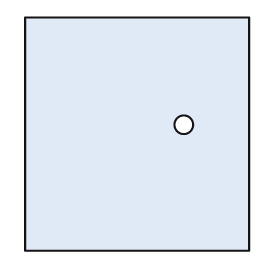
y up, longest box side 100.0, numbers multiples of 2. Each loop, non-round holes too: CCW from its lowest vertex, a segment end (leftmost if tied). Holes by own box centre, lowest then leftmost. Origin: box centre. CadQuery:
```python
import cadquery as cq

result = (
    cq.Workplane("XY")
    .moveTo(-48.0, -50.0)
    .lineTo(48.0, -50.0)
    .lineTo(48.0, 50.0)
    .lineTo(-48.0, 50.0)
    .close()
    .moveTo(20.0, 4.0)
    .circle(4.0)
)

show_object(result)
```